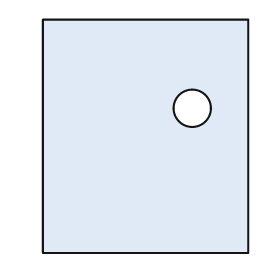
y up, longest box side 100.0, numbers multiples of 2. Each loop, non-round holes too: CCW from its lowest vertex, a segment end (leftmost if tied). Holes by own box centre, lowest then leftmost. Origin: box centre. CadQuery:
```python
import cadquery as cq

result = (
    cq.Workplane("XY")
    .moveTo(-44.0, -50.0)
    .lineTo(44.0, -50.0)
    .lineTo(44.0, 50.0)
    .lineTo(-44.0, 50.0)
    .close()
    .moveTo(20.0, 12.0)
    .circle(8.0)
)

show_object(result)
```